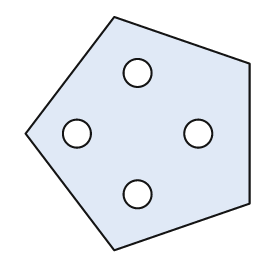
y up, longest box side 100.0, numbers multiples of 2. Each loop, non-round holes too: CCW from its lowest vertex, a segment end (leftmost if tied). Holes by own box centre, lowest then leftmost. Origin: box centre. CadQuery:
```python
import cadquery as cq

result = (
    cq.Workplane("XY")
    .moveTo(-10.0, -50.0)
    .lineTo(48.0, -30.0)
    .lineTo(48.0, 30.0)
    .lineTo(-10.0, 50.0)
    .lineTo(-48.0, 0.0)
    .close()
    .moveTo(0.0, -26.0)
    .circle(6.0)
    .moveTo(-26.0, 0.0)
    .circle(6.0)
    .moveTo(26.0, 0.0)
    .circle(6.0)
    .moveTo(0.0, 26.0)
    .circle(6.0)
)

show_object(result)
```